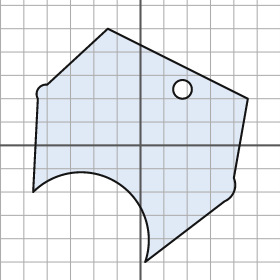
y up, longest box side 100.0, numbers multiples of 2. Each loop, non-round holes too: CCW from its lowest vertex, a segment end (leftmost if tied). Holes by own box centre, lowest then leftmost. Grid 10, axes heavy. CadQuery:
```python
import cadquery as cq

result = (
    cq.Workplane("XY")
    .moveTo(2.0, -50.0)
    .lineTo(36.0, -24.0)
    .threePointArc((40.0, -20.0), (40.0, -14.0))
    .lineTo(46.0, 20.0)
    .lineTo(-14.0, 50.0)
    .lineTo(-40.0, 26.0)
    .threePointArc((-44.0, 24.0), (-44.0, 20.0))
    .lineTo(-46.0, -20.0)
    .threePointArc((-10.0, -16.0), (2.0, -50.0))
    .close()
    .moveTo(18.0, 24.0)
    .circle(4.0)
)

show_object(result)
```